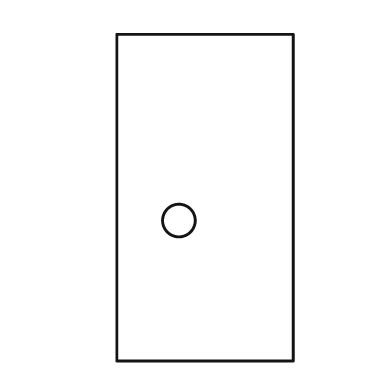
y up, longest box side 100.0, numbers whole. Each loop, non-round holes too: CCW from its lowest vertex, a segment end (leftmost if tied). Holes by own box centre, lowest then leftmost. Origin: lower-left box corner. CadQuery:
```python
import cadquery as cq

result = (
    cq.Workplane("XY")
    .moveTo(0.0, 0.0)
    .lineTo(54.0, 0.0)
    .lineTo(54.0, 100.0)
    .lineTo(0.0, 100.0)
    .close()
    .moveTo(19.0, 43.0)
    .circle(5.0)
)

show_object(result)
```